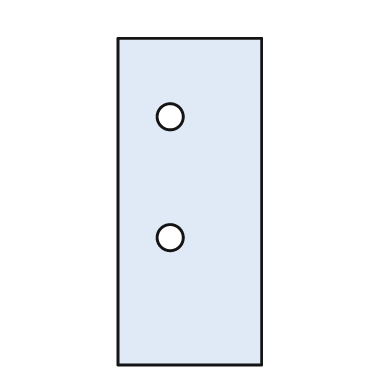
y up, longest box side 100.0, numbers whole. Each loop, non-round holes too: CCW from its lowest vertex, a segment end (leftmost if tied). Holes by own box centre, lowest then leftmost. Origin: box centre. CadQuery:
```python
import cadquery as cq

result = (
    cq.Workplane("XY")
    .moveTo(-22.0, -50.0)
    .lineTo(22.0, -50.0)
    .lineTo(22.0, 50.0)
    .lineTo(-22.0, 50.0)
    .close()
    .moveTo(-6.0, -11.0)
    .circle(4.0)
    .moveTo(-6.0, 26.0)
    .circle(4.0)
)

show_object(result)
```